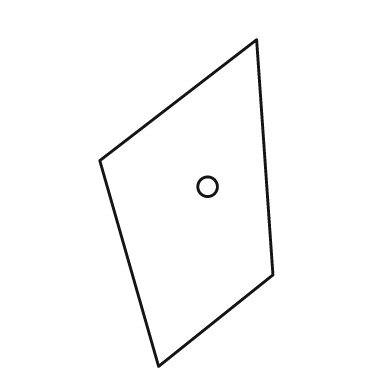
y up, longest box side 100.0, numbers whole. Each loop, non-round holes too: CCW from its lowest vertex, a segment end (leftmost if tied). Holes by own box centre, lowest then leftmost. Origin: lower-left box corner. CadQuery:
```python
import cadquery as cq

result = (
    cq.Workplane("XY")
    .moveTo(18.0, 0.0)
    .lineTo(53.0, 28.0)
    .lineTo(48.0, 100.0)
    .lineTo(0.0, 63.0)
    .close()
    .moveTo(33.0, 55.0)
    .circle(3.0)
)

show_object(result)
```